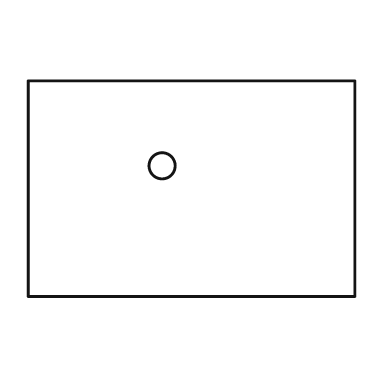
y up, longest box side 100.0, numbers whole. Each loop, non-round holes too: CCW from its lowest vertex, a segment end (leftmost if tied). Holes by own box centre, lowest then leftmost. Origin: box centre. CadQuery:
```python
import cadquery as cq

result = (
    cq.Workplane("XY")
    .moveTo(-50.0, -33.0)
    .lineTo(50.0, -33.0)
    .lineTo(50.0, 33.0)
    .lineTo(-50.0, 33.0)
    .close()
    .moveTo(-9.0, 7.0)
    .circle(4.0)
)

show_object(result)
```